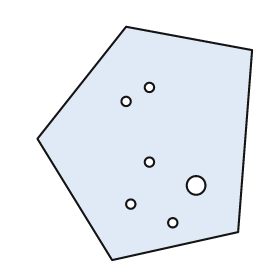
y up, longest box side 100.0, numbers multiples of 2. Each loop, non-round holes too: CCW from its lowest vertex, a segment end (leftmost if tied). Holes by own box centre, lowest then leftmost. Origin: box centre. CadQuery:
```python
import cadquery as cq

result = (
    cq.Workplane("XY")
    .moveTo(-14.0, -50.0)
    .lineTo(40.0, -38.0)
    .lineTo(46.0, 40.0)
    .lineTo(-8.0, 50.0)
    .lineTo(-46.0, 2.0)
    .close()
    .moveTo(12.0, -34.0)
    .circle(2.0)
    .moveTo(-6.0, -26.0)
    .circle(2.0)
    .moveTo(22.0, -18.0)
    .circle(4.0)
    .moveTo(2.0, -8.0)
    .circle(2.0)
    .moveTo(-8.0, 18.0)
    .circle(2.0)
    .moveTo(2.0, 24.0)
    .circle(2.0)
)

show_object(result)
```